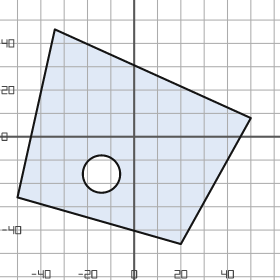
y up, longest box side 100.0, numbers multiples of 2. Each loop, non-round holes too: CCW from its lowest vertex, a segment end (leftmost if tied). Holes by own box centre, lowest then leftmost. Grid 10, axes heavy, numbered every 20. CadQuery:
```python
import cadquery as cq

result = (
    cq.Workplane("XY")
    .moveTo(20.0, -46.0)
    .lineTo(50.0, 8.0)
    .lineTo(-34.0, 46.0)
    .lineTo(-50.0, -26.0)
    .close()
    .moveTo(-14.0, -16.0)
    .circle(8.0)
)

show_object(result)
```